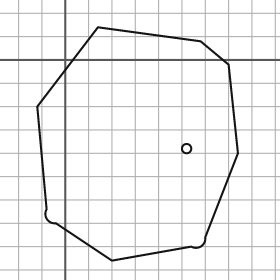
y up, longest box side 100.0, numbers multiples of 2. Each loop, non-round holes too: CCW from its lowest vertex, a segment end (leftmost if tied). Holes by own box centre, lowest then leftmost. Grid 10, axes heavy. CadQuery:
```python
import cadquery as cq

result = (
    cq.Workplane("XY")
    .moveTo(20.0, -86.0)
    .lineTo(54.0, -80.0)
    .threePointArc((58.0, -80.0), (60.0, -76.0))
    .lineTo(74.0, -40.0)
    .lineTo(70.0, -2.0)
    .lineTo(58.0, 8.0)
    .lineTo(14.0, 14.0)
    .lineTo(-12.0, -20.0)
    .lineTo(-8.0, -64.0)
    .threePointArc((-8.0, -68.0), (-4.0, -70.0))
    .close()
    .moveTo(52.0, -38.0)
    .circle(2.0)
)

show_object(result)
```